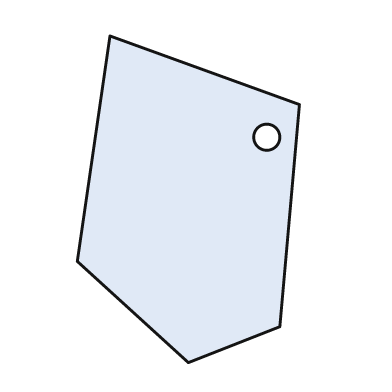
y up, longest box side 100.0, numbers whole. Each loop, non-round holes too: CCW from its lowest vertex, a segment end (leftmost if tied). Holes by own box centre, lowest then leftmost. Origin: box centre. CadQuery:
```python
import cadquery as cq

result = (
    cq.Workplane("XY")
    .moveTo(0.0, -50.0)
    .lineTo(28.0, -39.0)
    .lineTo(34.0, 29.0)
    .lineTo(-24.0, 50.0)
    .lineTo(-34.0, -19.0)
    .close()
    .moveTo(24.0, 19.0)
    .circle(4.0)
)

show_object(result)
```